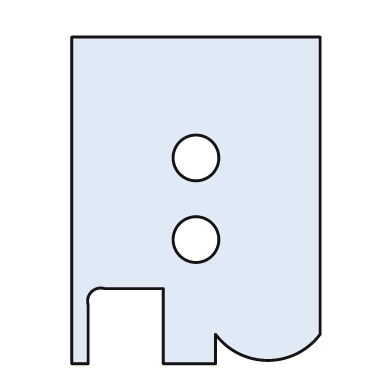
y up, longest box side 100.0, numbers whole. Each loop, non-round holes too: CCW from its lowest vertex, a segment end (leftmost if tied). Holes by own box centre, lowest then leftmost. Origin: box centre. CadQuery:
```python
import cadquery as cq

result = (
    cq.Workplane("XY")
    .moveTo(-38.0, -50.0)
    .lineTo(-33.0, -50.0)
    .lineTo(-33.0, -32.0)
    .threePointArc((-32.0, -28.0), (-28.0, -27.0))
    .lineTo(-10.0, -27.0)
    .lineTo(-10.0, -50.0)
    .lineTo(6.0, -50.0)
    .lineTo(6.0, -41.0)
    .threePointArc((22.0, -49.0), (38.0, -41.0))
    .lineTo(38.0, 50.0)
    .lineTo(-38.0, 50.0)
    .close()
    .moveTo(0.0, -12.0)
    .circle(7.0)
    .moveTo(0.0, 13.0)
    .circle(7.0)
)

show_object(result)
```